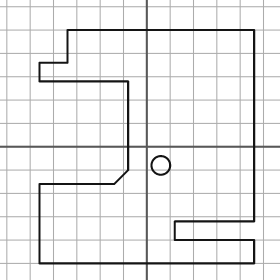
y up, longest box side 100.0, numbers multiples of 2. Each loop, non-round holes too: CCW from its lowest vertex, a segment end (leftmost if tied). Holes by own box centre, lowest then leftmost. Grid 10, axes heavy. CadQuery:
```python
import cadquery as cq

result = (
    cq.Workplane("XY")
    .moveTo(-46.0, -50.0)
    .lineTo(46.0, -50.0)
    .lineTo(46.0, -40.0)
    .lineTo(12.0, -40.0)
    .lineTo(12.0, -32.0)
    .lineTo(46.0, -32.0)
    .lineTo(46.0, 50.0)
    .lineTo(-34.0, 50.0)
    .lineTo(-34.0, 36.0)
    .lineTo(-46.0, 36.0)
    .lineTo(-46.0, 28.0)
    .lineTo(-8.0, 28.0)
    .lineTo(-8.0, -10.0)
    .lineTo(-14.0, -16.0)
    .lineTo(-46.0, -16.0)
    .close()
    .moveTo(6.0, -8.0)
    .circle(4.0)
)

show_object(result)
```